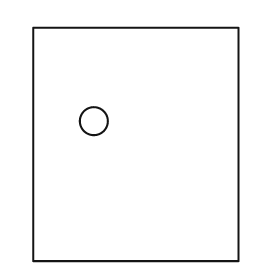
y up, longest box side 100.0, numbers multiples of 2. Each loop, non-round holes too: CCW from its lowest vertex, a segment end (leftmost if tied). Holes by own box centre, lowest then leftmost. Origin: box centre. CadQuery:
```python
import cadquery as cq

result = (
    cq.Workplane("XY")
    .moveTo(-44.0, -50.0)
    .lineTo(44.0, -50.0)
    .lineTo(44.0, 50.0)
    .lineTo(-44.0, 50.0)
    .close()
    .moveTo(-18.0, 10.0)
    .circle(6.0)
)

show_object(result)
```